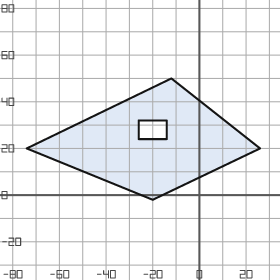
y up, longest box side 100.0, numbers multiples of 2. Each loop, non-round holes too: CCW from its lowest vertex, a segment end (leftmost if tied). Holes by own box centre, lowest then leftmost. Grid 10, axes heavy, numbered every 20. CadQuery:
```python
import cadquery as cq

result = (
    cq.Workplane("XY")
    .moveTo(-20.0, -2.0)
    .lineTo(26.0, 20.0)
    .lineTo(-12.0, 50.0)
    .lineTo(-74.0, 20.0)
    .close()
    .moveTo(-26.0, 24.0)
    .lineTo(-14.0, 24.0)
    .lineTo(-14.0, 32.0)
    .lineTo(-26.0, 32.0)
    .close()
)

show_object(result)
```